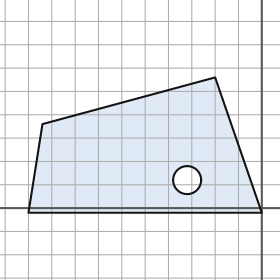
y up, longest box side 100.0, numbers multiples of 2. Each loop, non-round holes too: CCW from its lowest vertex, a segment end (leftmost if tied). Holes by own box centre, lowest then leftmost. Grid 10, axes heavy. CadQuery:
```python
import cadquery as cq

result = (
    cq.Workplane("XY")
    .moveTo(-100.0, -2.0)
    .lineTo(0.0, -2.0)
    .lineTo(-20.0, 56.0)
    .lineTo(-94.0, 36.0)
    .close()
    .moveTo(-32.0, 12.0)
    .circle(6.0)
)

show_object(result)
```